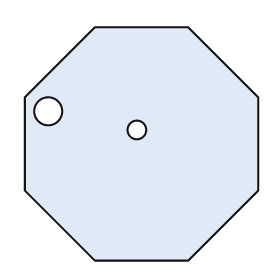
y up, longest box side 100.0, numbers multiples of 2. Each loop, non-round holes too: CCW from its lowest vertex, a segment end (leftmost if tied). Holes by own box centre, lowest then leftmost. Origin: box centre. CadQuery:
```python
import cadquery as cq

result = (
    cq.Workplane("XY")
    .moveTo(-20.0, -50.0)
    .lineTo(20.0, -50.0)
    .lineTo(50.0, -20.0)
    .lineTo(50.0, 20.0)
    .lineTo(20.0, 50.0)
    .lineTo(-20.0, 50.0)
    .lineTo(-50.0, 20.0)
    .lineTo(-50.0, -20.0)
    .close()
    .moveTo(-2.0, 6.0)
    .circle(4.0)
    .moveTo(-40.0, 14.0)
    .circle(6.0)
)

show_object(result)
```